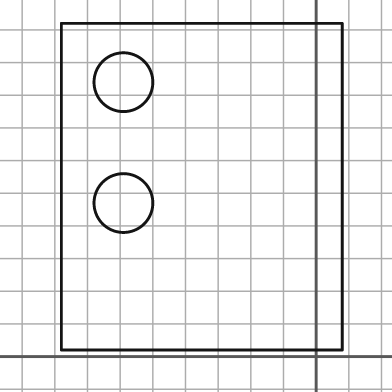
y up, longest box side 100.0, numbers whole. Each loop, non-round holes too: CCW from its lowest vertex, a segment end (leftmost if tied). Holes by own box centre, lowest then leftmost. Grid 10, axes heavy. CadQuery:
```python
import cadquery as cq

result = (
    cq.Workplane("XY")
    .moveTo(-78.0, 2.0)
    .lineTo(8.0, 2.0)
    .lineTo(8.0, 102.0)
    .lineTo(-78.0, 102.0)
    .close()
    .moveTo(-59.0, 47.0)
    .circle(9.0)
    .moveTo(-59.0, 84.0)
    .circle(9.0)
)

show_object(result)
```